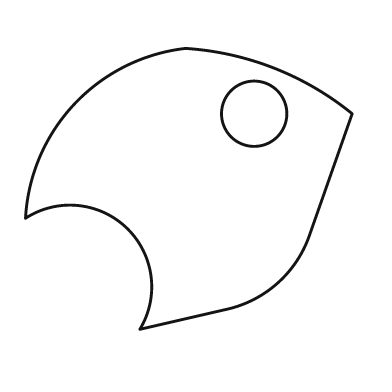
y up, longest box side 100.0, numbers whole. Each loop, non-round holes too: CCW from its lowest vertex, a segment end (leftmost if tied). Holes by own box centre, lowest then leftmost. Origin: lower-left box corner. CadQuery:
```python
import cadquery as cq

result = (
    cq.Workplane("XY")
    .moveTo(35.0, 0.0)
    .lineTo(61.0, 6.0)
    .threePointArc((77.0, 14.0), (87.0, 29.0))
    .lineTo(100.0, 66.0)
    .threePointArc((76.0, 80.0), (49.0, 86.0))
    .threePointArc((15.0, 69.0), (0.0, 34.0))
    .threePointArc((31.0, 31.0), (35.0, 0.0))
    .close()
    .moveTo(70.0, 66.0)
    .circle(10.0)
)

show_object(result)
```